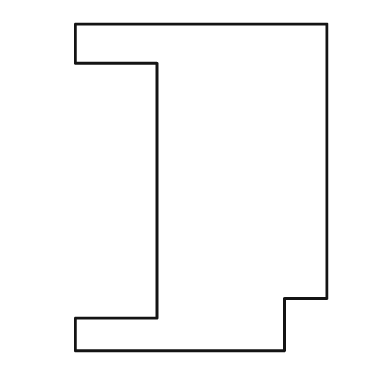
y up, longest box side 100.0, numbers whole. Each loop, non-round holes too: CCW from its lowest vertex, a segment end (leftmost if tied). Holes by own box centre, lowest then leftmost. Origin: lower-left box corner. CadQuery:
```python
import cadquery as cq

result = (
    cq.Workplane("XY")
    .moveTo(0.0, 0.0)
    .lineTo(64.0, 0.0)
    .lineTo(64.0, 16.0)
    .lineTo(77.0, 16.0)
    .lineTo(77.0, 100.0)
    .lineTo(0.0, 100.0)
    .lineTo(0.0, 88.0)
    .lineTo(25.0, 88.0)
    .lineTo(25.0, 10.0)
    .lineTo(0.0, 10.0)
    .close()
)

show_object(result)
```